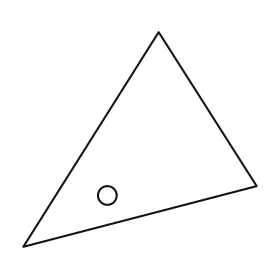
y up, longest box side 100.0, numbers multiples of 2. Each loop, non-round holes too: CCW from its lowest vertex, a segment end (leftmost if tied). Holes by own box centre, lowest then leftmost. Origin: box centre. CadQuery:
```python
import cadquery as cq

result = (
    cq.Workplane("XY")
    .moveTo(-50.0, -46.0)
    .lineTo(50.0, -20.0)
    .lineTo(8.0, 46.0)
    .close()
    .moveTo(-14.0, -24.0)
    .circle(4.0)
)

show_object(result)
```